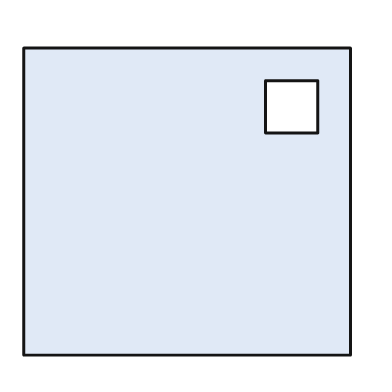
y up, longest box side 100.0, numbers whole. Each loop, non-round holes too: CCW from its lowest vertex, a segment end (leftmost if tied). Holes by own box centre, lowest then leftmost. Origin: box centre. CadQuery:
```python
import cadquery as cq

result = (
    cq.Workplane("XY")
    .moveTo(-50.0, -47.0)
    .lineTo(50.0, -47.0)
    .lineTo(50.0, 47.0)
    .lineTo(-50.0, 47.0)
    .close()
    .moveTo(24.0, 21.0)
    .lineTo(40.0, 21.0)
    .lineTo(40.0, 37.0)
    .lineTo(24.0, 37.0)
    .close()
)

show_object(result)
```